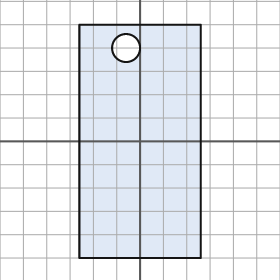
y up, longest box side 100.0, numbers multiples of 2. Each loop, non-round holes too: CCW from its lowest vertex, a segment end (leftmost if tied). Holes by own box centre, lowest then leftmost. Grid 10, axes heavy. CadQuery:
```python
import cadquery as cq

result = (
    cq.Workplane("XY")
    .moveTo(-26.0, -50.0)
    .lineTo(26.0, -50.0)
    .lineTo(26.0, 50.0)
    .lineTo(-26.0, 50.0)
    .close()
    .moveTo(-6.0, 40.0)
    .circle(6.0)
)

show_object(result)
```